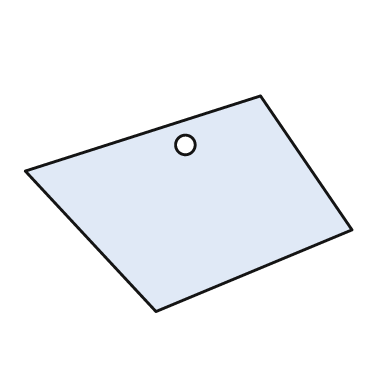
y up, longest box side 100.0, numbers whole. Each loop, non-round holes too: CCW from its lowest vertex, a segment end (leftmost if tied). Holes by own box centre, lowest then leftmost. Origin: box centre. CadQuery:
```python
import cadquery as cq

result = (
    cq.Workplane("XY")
    .moveTo(-10.0, -33.0)
    .lineTo(50.0, -8.0)
    .lineTo(22.0, 33.0)
    .lineTo(-50.0, 10.0)
    .close()
    .moveTo(-1.0, 18.0)
    .circle(3.0)
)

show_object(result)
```